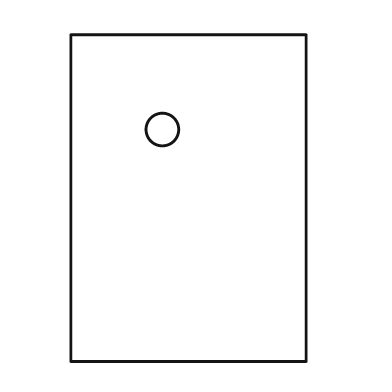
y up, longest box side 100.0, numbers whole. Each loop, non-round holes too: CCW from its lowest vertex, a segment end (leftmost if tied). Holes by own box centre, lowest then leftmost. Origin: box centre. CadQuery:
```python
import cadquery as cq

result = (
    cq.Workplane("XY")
    .moveTo(-36.0, -50.0)
    .lineTo(36.0, -50.0)
    .lineTo(36.0, 50.0)
    .lineTo(-36.0, 50.0)
    .close()
    .moveTo(-8.0, 21.0)
    .circle(5.0)
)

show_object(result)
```